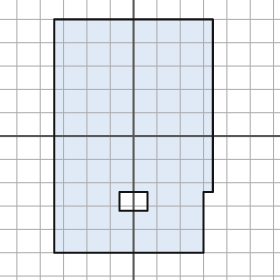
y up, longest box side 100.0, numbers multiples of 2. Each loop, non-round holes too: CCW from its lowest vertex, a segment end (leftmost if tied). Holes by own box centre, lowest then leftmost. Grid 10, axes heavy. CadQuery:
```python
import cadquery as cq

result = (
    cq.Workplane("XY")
    .moveTo(-34.0, -50.0)
    .lineTo(30.0, -50.0)
    .lineTo(30.0, -24.0)
    .lineTo(34.0, -24.0)
    .lineTo(34.0, 50.0)
    .lineTo(-34.0, 50.0)
    .close()
    .moveTo(-6.0, -32.0)
    .lineTo(6.0, -32.0)
    .lineTo(6.0, -24.0)
    .lineTo(-6.0, -24.0)
    .close()
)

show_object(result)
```